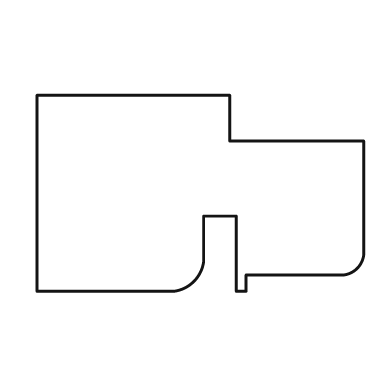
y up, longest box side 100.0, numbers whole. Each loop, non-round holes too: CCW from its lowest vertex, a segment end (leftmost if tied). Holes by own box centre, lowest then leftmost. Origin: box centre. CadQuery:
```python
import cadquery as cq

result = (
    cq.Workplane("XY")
    .moveTo(-50.0, -30.0)
    .lineTo(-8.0, -30.0)
    .threePointArc((-2.0, -27.0), (1.0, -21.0))
    .lineTo(1.0, -7.0)
    .lineTo(11.0, -7.0)
    .lineTo(11.0, -30.0)
    .lineTo(14.0, -30.0)
    .lineTo(14.0, -25.0)
    .lineTo(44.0, -25.0)
    .threePointArc((48.0, -23.0), (50.0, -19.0))
    .lineTo(50.0, 16.0)
    .lineTo(9.0, 16.0)
    .lineTo(9.0, 30.0)
    .lineTo(-50.0, 30.0)
    .close()
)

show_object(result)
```